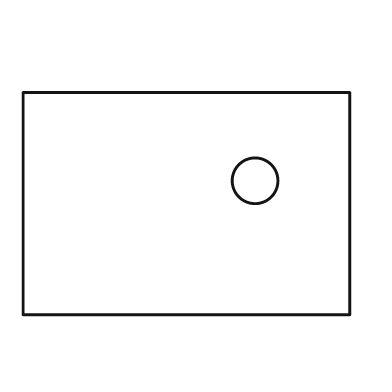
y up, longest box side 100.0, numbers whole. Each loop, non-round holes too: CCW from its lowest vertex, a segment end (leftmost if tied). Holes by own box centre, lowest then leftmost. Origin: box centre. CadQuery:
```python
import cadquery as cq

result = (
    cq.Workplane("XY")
    .moveTo(-50.0, -34.0)
    .lineTo(50.0, -34.0)
    .lineTo(50.0, 34.0)
    .lineTo(-50.0, 34.0)
    .close()
    .moveTo(21.0, 7.0)
    .circle(7.0)
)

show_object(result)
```